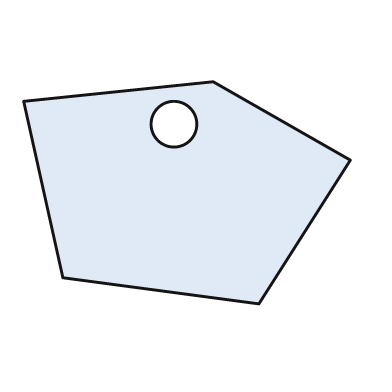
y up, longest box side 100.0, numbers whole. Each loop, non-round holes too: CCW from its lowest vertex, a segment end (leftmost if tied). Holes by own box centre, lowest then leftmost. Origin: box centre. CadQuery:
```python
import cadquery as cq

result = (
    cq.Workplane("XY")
    .moveTo(22.0, -34.0)
    .lineTo(50.0, 10.0)
    .lineTo(8.0, 34.0)
    .lineTo(-50.0, 28.0)
    .lineTo(-38.0, -26.0)
    .close()
    .moveTo(-4.0, 21.0)
    .circle(7.0)
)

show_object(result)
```